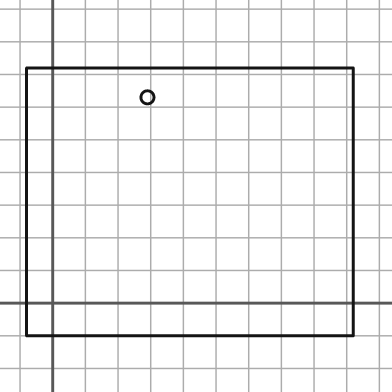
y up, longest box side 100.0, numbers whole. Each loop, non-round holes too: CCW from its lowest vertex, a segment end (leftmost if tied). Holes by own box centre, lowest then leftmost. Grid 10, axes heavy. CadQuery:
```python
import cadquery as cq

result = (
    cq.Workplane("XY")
    .moveTo(-8.0, -10.0)
    .lineTo(92.0, -10.0)
    .lineTo(92.0, 72.0)
    .lineTo(-8.0, 72.0)
    .close()
    .moveTo(29.0, 63.0)
    .circle(2.0)
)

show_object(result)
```